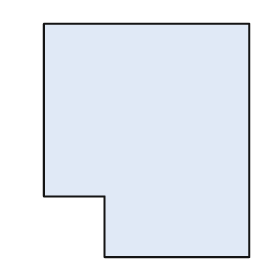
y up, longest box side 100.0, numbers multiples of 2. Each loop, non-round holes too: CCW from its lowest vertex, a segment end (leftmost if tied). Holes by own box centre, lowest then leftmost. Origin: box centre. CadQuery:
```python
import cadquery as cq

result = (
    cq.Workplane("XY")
    .moveTo(-18.0, -50.0)
    .lineTo(44.0, -50.0)
    .lineTo(44.0, 50.0)
    .lineTo(-44.0, 50.0)
    .lineTo(-44.0, -24.0)
    .lineTo(-18.0, -24.0)
    .close()
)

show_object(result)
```